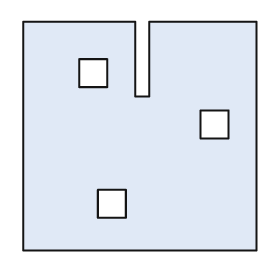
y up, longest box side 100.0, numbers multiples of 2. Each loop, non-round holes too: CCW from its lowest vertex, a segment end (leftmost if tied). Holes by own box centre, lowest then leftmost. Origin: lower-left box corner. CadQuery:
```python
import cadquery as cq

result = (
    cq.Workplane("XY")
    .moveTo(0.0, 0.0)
    .lineTo(100.0, 0.0)
    .lineTo(100.0, 98.0)
    .lineTo(54.0, 98.0)
    .lineTo(54.0, 66.0)
    .lineTo(48.0, 66.0)
    .lineTo(48.0, 98.0)
    .lineTo(0.0, 98.0)
    .close()
    .moveTo(32.0, 14.0)
    .lineTo(44.0, 14.0)
    .lineTo(44.0, 26.0)
    .lineTo(32.0, 26.0)
    .close()
    .moveTo(76.0, 48.0)
    .lineTo(88.0, 48.0)
    .lineTo(88.0, 60.0)
    .lineTo(76.0, 60.0)
    .close()
    .moveTo(24.0, 70.0)
    .lineTo(36.0, 70.0)
    .lineTo(36.0, 82.0)
    .lineTo(24.0, 82.0)
    .close()
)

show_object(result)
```